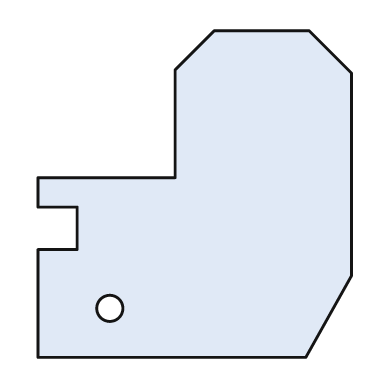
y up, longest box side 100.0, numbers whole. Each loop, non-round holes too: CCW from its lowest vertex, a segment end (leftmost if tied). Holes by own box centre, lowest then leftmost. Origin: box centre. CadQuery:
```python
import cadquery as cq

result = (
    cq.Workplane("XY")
    .moveTo(-48.0, -50.0)
    .lineTo(34.0, -50.0)
    .lineTo(48.0, -25.0)
    .lineTo(48.0, 37.0)
    .lineTo(35.0, 50.0)
    .lineTo(6.0, 50.0)
    .lineTo(-6.0, 38.0)
    .lineTo(-6.0, 5.0)
    .lineTo(-48.0, 5.0)
    .lineTo(-48.0, -4.0)
    .lineTo(-36.0, -4.0)
    .lineTo(-36.0, -17.0)
    .lineTo(-48.0, -17.0)
    .close()
    .moveTo(-26.0, -35.0)
    .circle(4.0)
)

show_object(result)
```